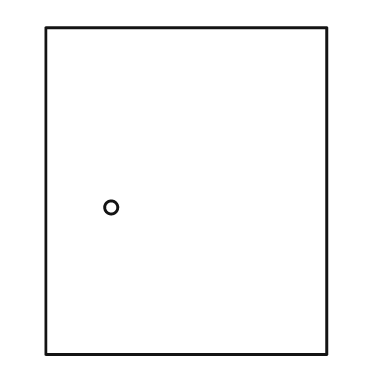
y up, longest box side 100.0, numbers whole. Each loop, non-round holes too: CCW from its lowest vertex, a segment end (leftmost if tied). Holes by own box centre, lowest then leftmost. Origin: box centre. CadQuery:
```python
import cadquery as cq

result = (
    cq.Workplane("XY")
    .moveTo(-43.0, -50.0)
    .lineTo(43.0, -50.0)
    .lineTo(43.0, 50.0)
    .lineTo(-43.0, 50.0)
    .close()
    .moveTo(-23.0, -5.0)
    .circle(2.0)
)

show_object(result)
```